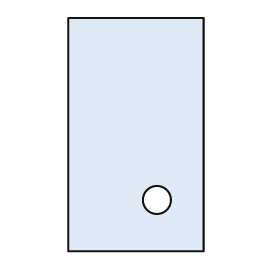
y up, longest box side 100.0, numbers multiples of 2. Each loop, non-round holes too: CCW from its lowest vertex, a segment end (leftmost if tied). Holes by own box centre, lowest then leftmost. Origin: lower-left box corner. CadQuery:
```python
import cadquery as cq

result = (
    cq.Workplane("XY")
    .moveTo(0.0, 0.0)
    .lineTo(58.0, 0.0)
    .lineTo(58.0, 100.0)
    .lineTo(0.0, 100.0)
    .close()
    .moveTo(38.0, 22.0)
    .circle(6.0)
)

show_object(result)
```